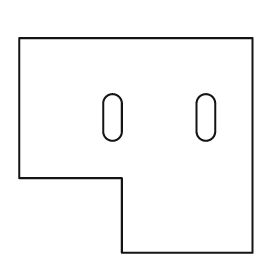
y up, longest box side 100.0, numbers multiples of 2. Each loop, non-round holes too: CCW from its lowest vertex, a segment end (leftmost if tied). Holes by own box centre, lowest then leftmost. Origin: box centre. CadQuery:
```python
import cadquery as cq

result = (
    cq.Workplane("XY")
    .moveTo(-6.0, -46.0)
    .lineTo(50.0, -46.0)
    .lineTo(50.0, 46.0)
    .lineTo(-50.0, 46.0)
    .lineTo(-50.0, -14.0)
    .lineTo(-6.0, -14.0)
    .close()
    .moveTo(-14.0, 6.0)
    .threePointArc((-10.0, 2.0), (-6.0, 6.0))
    .lineTo(-6.0, 18.0)
    .threePointArc((-10.0, 22.0), (-14.0, 18.0))
    .close()
    .moveTo(26.0, 6.0)
    .threePointArc((30.0, 2.0), (34.0, 6.0))
    .lineTo(34.0, 18.0)
    .threePointArc((30.0, 22.0), (26.0, 18.0))
    .close()
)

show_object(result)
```